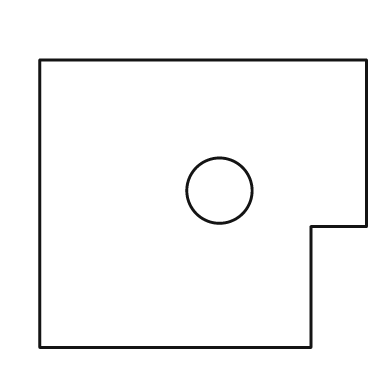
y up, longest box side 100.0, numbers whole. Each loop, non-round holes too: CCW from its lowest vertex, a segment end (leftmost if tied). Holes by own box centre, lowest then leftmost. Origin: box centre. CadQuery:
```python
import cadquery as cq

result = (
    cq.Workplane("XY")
    .moveTo(-50.0, -44.0)
    .lineTo(33.0, -44.0)
    .lineTo(33.0, -7.0)
    .lineTo(50.0, -7.0)
    .lineTo(50.0, 44.0)
    .lineTo(-50.0, 44.0)
    .close()
    .moveTo(5.0, 4.0)
    .circle(10.0)
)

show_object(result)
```